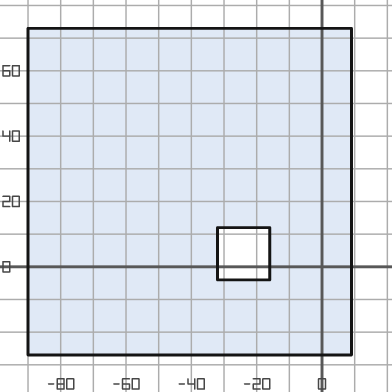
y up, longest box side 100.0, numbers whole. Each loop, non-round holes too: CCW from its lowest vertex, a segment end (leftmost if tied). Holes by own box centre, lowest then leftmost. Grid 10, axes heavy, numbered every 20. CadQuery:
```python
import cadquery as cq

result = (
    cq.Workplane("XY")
    .moveTo(-90.0, -27.0)
    .lineTo(9.0, -27.0)
    .lineTo(9.0, 73.0)
    .lineTo(-90.0, 73.0)
    .close()
    .moveTo(-32.0, -4.0)
    .lineTo(-16.0, -4.0)
    .lineTo(-16.0, 12.0)
    .lineTo(-32.0, 12.0)
    .close()
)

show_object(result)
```